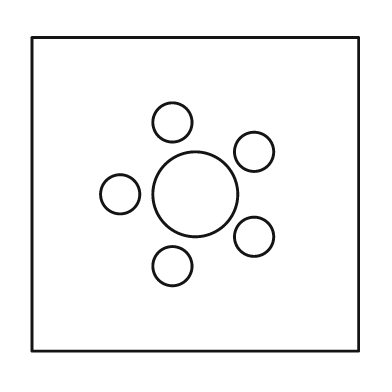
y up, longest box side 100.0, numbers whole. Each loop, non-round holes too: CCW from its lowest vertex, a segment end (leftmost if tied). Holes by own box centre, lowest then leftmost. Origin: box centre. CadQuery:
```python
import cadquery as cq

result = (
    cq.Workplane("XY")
    .moveTo(-50.0, -48.0)
    .lineTo(50.0, -48.0)
    .lineTo(50.0, 48.0)
    .lineTo(-50.0, 48.0)
    .close()
    .moveTo(-7.0, -22.0)
    .circle(6.0)
    .moveTo(18.0, -13.0)
    .circle(6.0)
    .moveTo(-23.0, 0.0)
    .circle(6.0)
    .moveTo(0.0, 0.0)
    .circle(13.0)
    .moveTo(18.0, 13.0)
    .circle(6.0)
    .moveTo(-7.0, 22.0)
    .circle(6.0)
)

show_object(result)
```